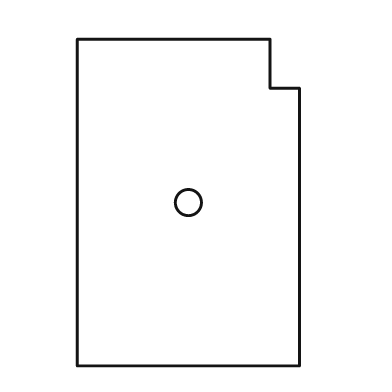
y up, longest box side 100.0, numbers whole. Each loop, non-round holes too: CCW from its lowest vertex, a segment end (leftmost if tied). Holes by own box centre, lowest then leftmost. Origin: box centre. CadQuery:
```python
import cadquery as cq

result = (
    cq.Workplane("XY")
    .moveTo(-34.0, -50.0)
    .lineTo(34.0, -50.0)
    .lineTo(34.0, 35.0)
    .lineTo(25.0, 35.0)
    .lineTo(25.0, 50.0)
    .lineTo(-34.0, 50.0)
    .close()
    .moveTo(0.0, 0.0)
    .circle(4.0)
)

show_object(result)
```